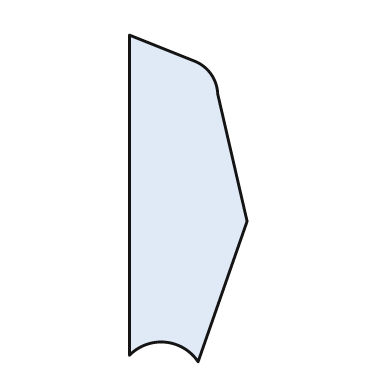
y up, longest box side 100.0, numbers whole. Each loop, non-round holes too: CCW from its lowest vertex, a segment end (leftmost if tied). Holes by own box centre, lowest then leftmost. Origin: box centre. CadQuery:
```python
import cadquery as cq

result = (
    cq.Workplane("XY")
    .moveTo(3.0, -50.0)
    .lineTo(18.0, -7.0)
    .lineTo(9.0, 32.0)
    .threePointArc((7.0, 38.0), (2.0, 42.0))
    .lineTo(-18.0, 50.0)
    .lineTo(-18.0, -48.0)
    .threePointArc((-7.0, -44.0), (3.0, -50.0))
    .close()
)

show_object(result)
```